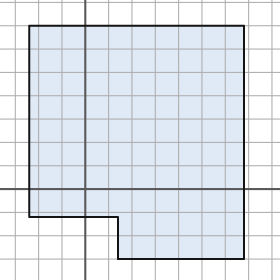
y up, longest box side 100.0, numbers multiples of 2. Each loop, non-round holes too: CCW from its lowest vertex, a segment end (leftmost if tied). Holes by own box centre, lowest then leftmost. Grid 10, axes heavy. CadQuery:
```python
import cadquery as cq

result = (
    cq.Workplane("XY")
    .moveTo(14.0, -30.0)
    .lineTo(68.0, -30.0)
    .lineTo(68.0, 70.0)
    .lineTo(-24.0, 70.0)
    .lineTo(-24.0, -12.0)
    .lineTo(14.0, -12.0)
    .close()
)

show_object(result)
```